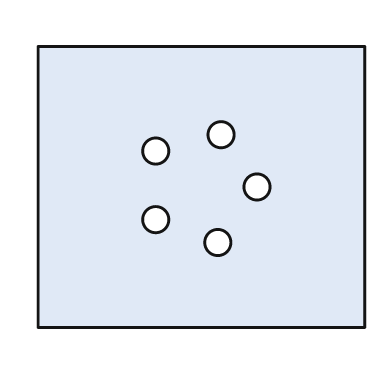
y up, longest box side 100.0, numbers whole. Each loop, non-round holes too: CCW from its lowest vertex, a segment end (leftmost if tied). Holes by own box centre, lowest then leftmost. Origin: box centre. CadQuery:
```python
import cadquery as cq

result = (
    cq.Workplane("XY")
    .moveTo(-50.0, -43.0)
    .lineTo(50.0, -43.0)
    .lineTo(50.0, 43.0)
    .lineTo(-50.0, 43.0)
    .close()
    .moveTo(5.0, -17.0)
    .circle(4.0)
    .moveTo(-14.0, -10.0)
    .circle(4.0)
    .moveTo(17.0, 0.0)
    .circle(4.0)
    .moveTo(-14.0, 11.0)
    .circle(4.0)
    .moveTo(6.0, 16.0)
    .circle(4.0)
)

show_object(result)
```